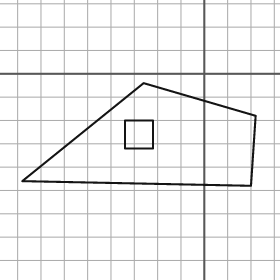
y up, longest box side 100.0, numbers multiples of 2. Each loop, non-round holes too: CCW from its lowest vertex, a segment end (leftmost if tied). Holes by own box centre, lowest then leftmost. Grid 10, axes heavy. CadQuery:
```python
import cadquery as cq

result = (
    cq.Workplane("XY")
    .moveTo(20.0, -48.0)
    .lineTo(22.0, -18.0)
    .lineTo(-26.0, -4.0)
    .lineTo(-78.0, -46.0)
    .close()
    .moveTo(-34.0, -32.0)
    .lineTo(-22.0, -32.0)
    .lineTo(-22.0, -20.0)
    .lineTo(-34.0, -20.0)
    .close()
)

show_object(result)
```